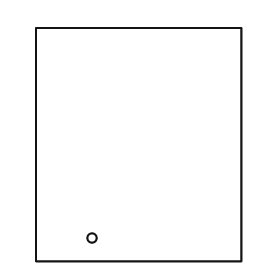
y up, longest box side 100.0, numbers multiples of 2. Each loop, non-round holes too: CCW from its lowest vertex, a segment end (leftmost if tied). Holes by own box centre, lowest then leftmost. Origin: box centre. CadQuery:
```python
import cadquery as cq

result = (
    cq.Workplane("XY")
    .moveTo(-44.0, -50.0)
    .lineTo(44.0, -50.0)
    .lineTo(44.0, 50.0)
    .lineTo(-44.0, 50.0)
    .close()
    .moveTo(-20.0, -40.0)
    .circle(2.0)
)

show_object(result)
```